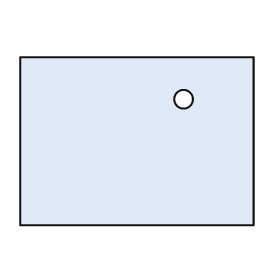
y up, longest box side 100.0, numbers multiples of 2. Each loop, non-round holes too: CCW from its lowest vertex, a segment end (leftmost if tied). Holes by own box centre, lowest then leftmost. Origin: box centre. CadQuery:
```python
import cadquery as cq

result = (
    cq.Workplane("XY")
    .moveTo(-50.0, -36.0)
    .lineTo(50.0, -36.0)
    .lineTo(50.0, 36.0)
    .lineTo(-50.0, 36.0)
    .close()
    .moveTo(20.0, 18.0)
    .circle(4.0)
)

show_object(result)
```